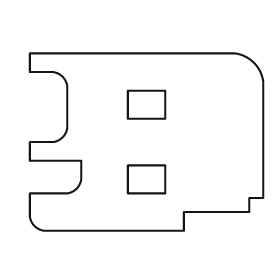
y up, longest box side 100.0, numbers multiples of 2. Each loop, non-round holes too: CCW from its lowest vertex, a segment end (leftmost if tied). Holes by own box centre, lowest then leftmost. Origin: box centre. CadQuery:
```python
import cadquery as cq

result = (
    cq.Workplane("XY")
    .moveTo(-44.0, -38.0)
    .lineTo(16.0, -38.0)
    .lineTo(16.0, -30.0)
    .lineTo(44.0, -30.0)
    .lineTo(44.0, -24.0)
    .lineTo(50.0, -24.0)
    .lineTo(50.0, 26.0)
    .threePointArc((46.0, 34.0), (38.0, 38.0))
    .lineTo(-50.0, 38.0)
    .lineTo(-50.0, 30.0)
    .lineTo(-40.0, 30.0)
    .threePointArc((-36.0, 28.0), (-34.0, 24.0))
    .lineTo(-34.0, 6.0)
    .threePointArc((-36.0, 2.0), (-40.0, 0.0))
    .lineTo(-50.0, 0.0)
    .lineTo(-50.0, -8.0)
    .lineTo(-28.0, -8.0)
    .lineTo(-28.0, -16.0)
    .threePointArc((-30.0, -20.0), (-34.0, -22.0))
    .lineTo(-50.0, -22.0)
    .lineTo(-50.0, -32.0)
    .threePointArc((-48.0, -36.0), (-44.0, -38.0))
    .close()
    .moveTo(-8.0, -22.0)
    .lineTo(8.0, -22.0)
    .lineTo(8.0, -10.0)
    .lineTo(-8.0, -10.0)
    .close()
    .moveTo(-8.0, 10.0)
    .lineTo(8.0, 10.0)
    .lineTo(8.0, 22.0)
    .lineTo(-8.0, 22.0)
    .close()
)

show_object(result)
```